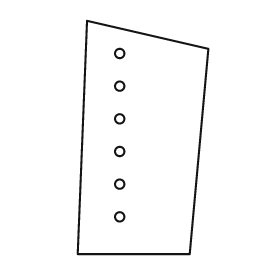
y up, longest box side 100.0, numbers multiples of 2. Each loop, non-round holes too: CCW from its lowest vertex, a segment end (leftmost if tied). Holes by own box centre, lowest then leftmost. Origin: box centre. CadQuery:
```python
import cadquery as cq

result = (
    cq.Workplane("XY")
    .moveTo(-28.0, -50.0)
    .lineTo(20.0, -50.0)
    .lineTo(28.0, 38.0)
    .lineTo(-24.0, 50.0)
    .close()
    .moveTo(-10.0, -34.0)
    .circle(2.0)
    .moveTo(-10.0, -20.0)
    .circle(2.0)
    .moveTo(-10.0, -6.0)
    .circle(2.0)
    .moveTo(-10.0, 8.0)
    .circle(2.0)
    .moveTo(-10.0, 22.0)
    .circle(2.0)
    .moveTo(-10.0, 36.0)
    .circle(2.0)
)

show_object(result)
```